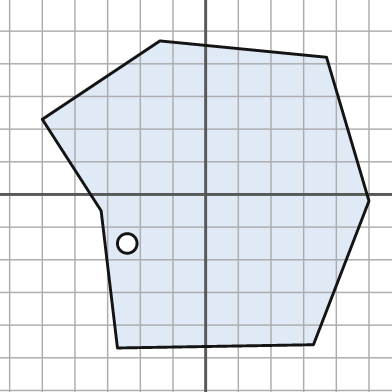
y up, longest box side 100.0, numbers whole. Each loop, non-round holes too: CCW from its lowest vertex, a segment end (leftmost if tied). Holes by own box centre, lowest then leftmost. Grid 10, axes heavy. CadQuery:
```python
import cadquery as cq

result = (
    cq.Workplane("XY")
    .moveTo(-27.0, -47.0)
    .lineTo(33.0, -46.0)
    .lineTo(50.0, -2.0)
    .lineTo(37.0, 42.0)
    .lineTo(-14.0, 47.0)
    .lineTo(-50.0, 23.0)
    .lineTo(-32.0, -5.0)
    .close()
    .moveTo(-24.0, -15.0)
    .circle(3.0)
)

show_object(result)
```